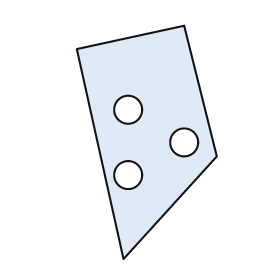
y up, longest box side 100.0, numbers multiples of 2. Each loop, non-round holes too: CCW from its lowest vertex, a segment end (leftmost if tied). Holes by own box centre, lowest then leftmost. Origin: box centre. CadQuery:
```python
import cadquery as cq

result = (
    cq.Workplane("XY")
    .moveTo(-10.0, -50.0)
    .lineTo(30.0, -6.0)
    .lineTo(16.0, 50.0)
    .lineTo(-30.0, 40.0)
    .close()
    .moveTo(-8.0, -14.0)
    .circle(6.0)
    .moveTo(16.0, 0.0)
    .circle(6.0)
    .moveTo(-8.0, 14.0)
    .circle(6.0)
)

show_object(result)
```